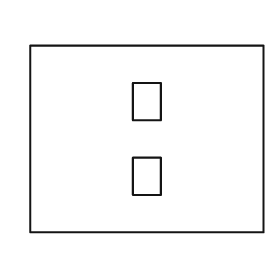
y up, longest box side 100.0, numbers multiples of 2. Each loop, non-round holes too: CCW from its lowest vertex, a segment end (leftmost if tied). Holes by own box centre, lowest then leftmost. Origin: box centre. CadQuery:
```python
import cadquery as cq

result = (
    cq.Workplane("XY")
    .moveTo(-50.0, -40.0)
    .lineTo(50.0, -40.0)
    .lineTo(50.0, 40.0)
    .lineTo(-50.0, 40.0)
    .close()
    .moveTo(-6.0, -24.0)
    .lineTo(6.0, -24.0)
    .lineTo(6.0, -8.0)
    .lineTo(-6.0, -8.0)
    .close()
    .moveTo(-6.0, 8.0)
    .lineTo(6.0, 8.0)
    .lineTo(6.0, 24.0)
    .lineTo(-6.0, 24.0)
    .close()
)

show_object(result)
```